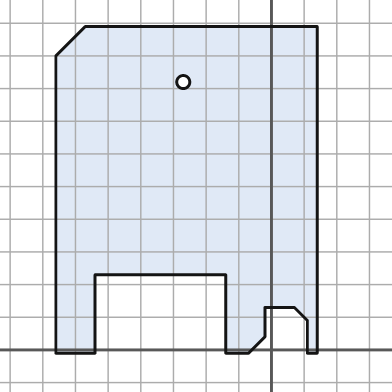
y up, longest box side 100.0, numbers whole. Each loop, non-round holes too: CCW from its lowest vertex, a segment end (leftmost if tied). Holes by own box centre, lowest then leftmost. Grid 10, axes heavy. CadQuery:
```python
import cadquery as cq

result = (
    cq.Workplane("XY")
    .moveTo(-66.0, -1.0)
    .lineTo(-54.0, -1.0)
    .lineTo(-54.0, 23.0)
    .lineTo(-14.0, 23.0)
    .lineTo(-14.0, -1.0)
    .lineTo(-7.0, -1.0)
    .lineTo(-2.0, 4.0)
    .lineTo(-2.0, 13.0)
    .lineTo(7.0, 13.0)
    .lineTo(11.0, 9.0)
    .lineTo(11.0, -1.0)
    .lineTo(14.0, -1.0)
    .lineTo(14.0, 99.0)
    .lineTo(-57.0, 99.0)
    .lineTo(-66.0, 90.0)
    .close()
    .moveTo(-27.0, 82.0)
    .circle(2.0)
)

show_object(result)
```